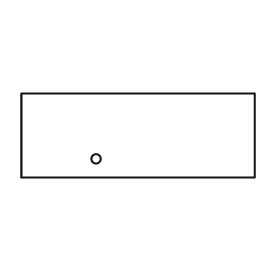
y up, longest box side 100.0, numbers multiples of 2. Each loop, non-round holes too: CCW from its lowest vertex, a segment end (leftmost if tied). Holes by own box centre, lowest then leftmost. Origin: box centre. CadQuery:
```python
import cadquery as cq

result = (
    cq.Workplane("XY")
    .moveTo(-50.0, -18.0)
    .lineTo(50.0, -18.0)
    .lineTo(50.0, 18.0)
    .lineTo(-50.0, 18.0)
    .close()
    .moveTo(-18.0, -10.0)
    .circle(2.0)
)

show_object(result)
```